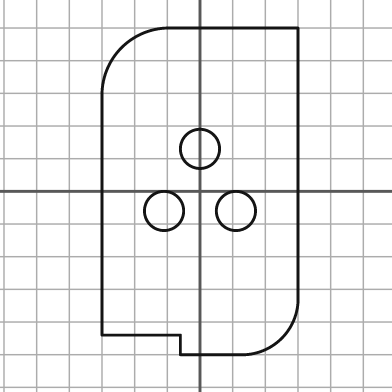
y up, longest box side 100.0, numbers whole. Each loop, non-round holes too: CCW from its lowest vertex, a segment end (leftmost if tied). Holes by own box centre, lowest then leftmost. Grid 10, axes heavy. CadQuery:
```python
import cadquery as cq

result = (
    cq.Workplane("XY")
    .moveTo(-6.0, -50.0)
    .lineTo(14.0, -50.0)
    .threePointArc((25.0, -45.0), (30.0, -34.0))
    .lineTo(30.0, 50.0)
    .lineTo(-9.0, 50.0)
    .threePointArc((-24.0, 44.0), (-30.0, 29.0))
    .lineTo(-30.0, -44.0)
    .lineTo(-6.0, -44.0)
    .close()
    .moveTo(-11.0, -6.0)
    .circle(6.0)
    .moveTo(11.0, -6.0)
    .circle(6.0)
    .moveTo(0.0, 13.0)
    .circle(6.0)
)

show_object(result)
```